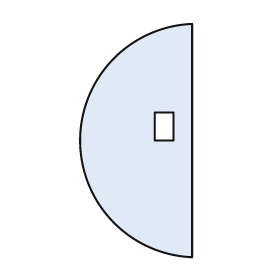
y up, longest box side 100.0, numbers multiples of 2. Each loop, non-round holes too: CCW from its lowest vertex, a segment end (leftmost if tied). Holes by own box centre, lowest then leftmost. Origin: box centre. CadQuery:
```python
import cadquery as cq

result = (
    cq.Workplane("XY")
    .moveTo(24.0, -50.0)
    .lineTo(24.0, 50.0)
    .threePointArc((-24.0, 0.0), (24.0, -50.0))
    .close()
    .moveTo(8.0, 0.0)
    .lineTo(16.0, 0.0)
    .lineTo(16.0, 12.0)
    .lineTo(8.0, 12.0)
    .close()
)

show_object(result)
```